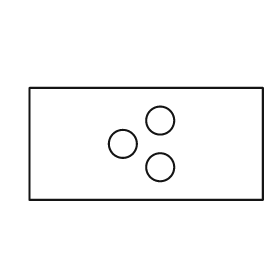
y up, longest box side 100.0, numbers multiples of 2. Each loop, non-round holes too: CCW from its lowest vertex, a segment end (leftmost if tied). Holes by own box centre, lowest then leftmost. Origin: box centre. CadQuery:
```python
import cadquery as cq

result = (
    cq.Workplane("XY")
    .moveTo(-50.0, -24.0)
    .lineTo(50.0, -24.0)
    .lineTo(50.0, 24.0)
    .lineTo(-50.0, 24.0)
    .close()
    .moveTo(6.0, -10.0)
    .circle(6.0)
    .moveTo(-10.0, 0.0)
    .circle(6.0)
    .moveTo(6.0, 10.0)
    .circle(6.0)
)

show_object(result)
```